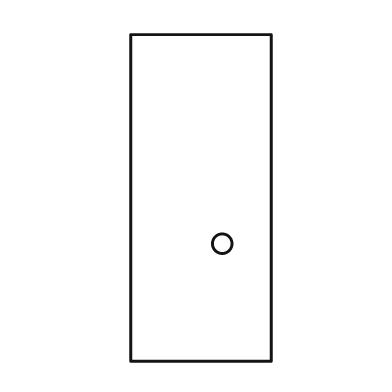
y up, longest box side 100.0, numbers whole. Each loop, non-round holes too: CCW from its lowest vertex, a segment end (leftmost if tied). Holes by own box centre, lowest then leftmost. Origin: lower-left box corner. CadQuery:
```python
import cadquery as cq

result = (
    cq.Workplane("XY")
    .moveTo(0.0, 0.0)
    .lineTo(43.0, 0.0)
    .lineTo(43.0, 100.0)
    .lineTo(0.0, 100.0)
    .close()
    .moveTo(28.0, 36.0)
    .circle(3.0)
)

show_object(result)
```